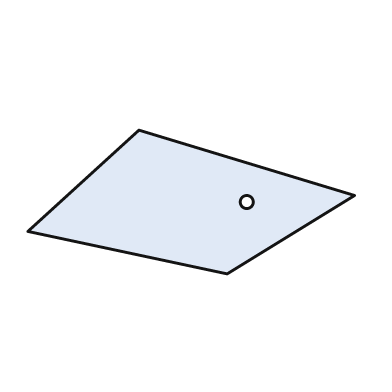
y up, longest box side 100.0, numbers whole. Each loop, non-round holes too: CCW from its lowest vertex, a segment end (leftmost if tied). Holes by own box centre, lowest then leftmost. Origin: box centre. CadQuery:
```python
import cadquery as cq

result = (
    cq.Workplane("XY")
    .moveTo(11.0, -22.0)
    .lineTo(50.0, 2.0)
    .lineTo(-16.0, 22.0)
    .lineTo(-50.0, -9.0)
    .close()
    .moveTo(17.0, 0.0)
    .circle(2.0)
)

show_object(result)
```